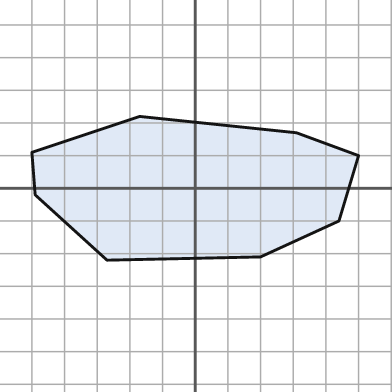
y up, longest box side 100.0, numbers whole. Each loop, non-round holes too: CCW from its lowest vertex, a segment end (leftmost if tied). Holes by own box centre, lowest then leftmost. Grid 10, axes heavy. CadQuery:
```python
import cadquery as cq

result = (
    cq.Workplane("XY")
    .moveTo(-27.0, -22.0)
    .lineTo(20.0, -21.0)
    .lineTo(44.0, -10.0)
    .lineTo(50.0, 10.0)
    .lineTo(31.0, 17.0)
    .lineTo(-17.0, 22.0)
    .lineTo(-50.0, 11.0)
    .lineTo(-49.0, -2.0)
    .close()
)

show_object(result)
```